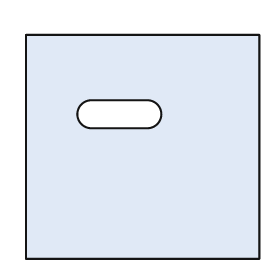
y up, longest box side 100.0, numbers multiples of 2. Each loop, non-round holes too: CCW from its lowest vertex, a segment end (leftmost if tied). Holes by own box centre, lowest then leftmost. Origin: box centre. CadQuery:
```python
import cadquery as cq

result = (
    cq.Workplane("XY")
    .moveTo(-50.0, -48.0)
    .lineTo(50.0, -48.0)
    .lineTo(50.0, 48.0)
    .lineTo(-50.0, 48.0)
    .close()
    .moveTo(-22.0, 8.0)
    .lineTo(2.0, 8.0)
    .threePointArc((8.0, 14.0), (2.0, 20.0))
    .lineTo(-22.0, 20.0)
    .threePointArc((-28.0, 14.0), (-22.0, 8.0))
    .close()
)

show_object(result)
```